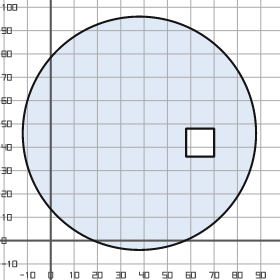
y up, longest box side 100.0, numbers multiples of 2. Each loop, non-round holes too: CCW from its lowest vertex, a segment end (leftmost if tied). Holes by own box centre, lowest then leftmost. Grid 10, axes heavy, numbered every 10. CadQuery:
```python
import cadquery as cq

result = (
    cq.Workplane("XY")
    .moveTo(38.0, 46.0)
    .circle(50.0)
    .moveTo(58.0, 36.0)
    .lineTo(70.0, 36.0)
    .lineTo(70.0, 48.0)
    .lineTo(58.0, 48.0)
    .close()
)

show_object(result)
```